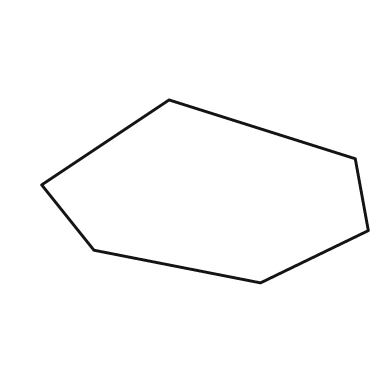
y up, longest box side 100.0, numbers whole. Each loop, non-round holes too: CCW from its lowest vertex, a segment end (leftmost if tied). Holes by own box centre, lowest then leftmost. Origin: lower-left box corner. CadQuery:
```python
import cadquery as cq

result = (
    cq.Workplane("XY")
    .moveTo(67.0, 0.0)
    .lineTo(100.0, 16.0)
    .lineTo(96.0, 38.0)
    .lineTo(39.0, 56.0)
    .lineTo(0.0, 30.0)
    .lineTo(16.0, 10.0)
    .close()
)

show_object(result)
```